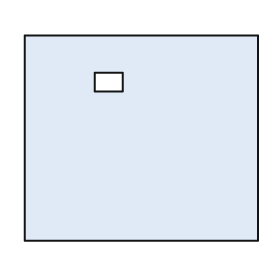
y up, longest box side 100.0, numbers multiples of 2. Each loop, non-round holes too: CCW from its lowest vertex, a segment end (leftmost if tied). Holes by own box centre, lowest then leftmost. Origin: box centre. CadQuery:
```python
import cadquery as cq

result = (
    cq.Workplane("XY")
    .moveTo(-50.0, -44.0)
    .lineTo(50.0, -44.0)
    .lineTo(50.0, 44.0)
    .lineTo(-50.0, 44.0)
    .close()
    .moveTo(-20.0, 20.0)
    .lineTo(-8.0, 20.0)
    .lineTo(-8.0, 28.0)
    .lineTo(-20.0, 28.0)
    .close()
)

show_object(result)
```